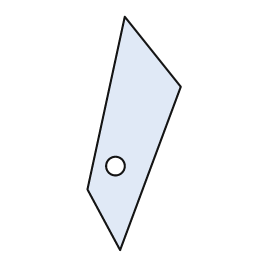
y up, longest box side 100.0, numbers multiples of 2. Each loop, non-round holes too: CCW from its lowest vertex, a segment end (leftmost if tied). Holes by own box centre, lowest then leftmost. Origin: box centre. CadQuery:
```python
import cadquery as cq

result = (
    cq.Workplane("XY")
    .moveTo(-6.0, -50.0)
    .lineTo(20.0, 20.0)
    .lineTo(-4.0, 50.0)
    .lineTo(-20.0, -24.0)
    .close()
    .moveTo(-8.0, -14.0)
    .circle(4.0)
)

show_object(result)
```